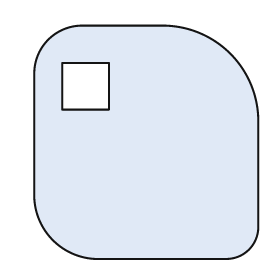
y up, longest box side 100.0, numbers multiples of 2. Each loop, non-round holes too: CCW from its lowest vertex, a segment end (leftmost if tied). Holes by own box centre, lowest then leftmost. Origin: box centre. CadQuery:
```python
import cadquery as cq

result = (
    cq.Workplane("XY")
    .moveTo(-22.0, -50.0)
    .lineTo(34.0, -50.0)
    .threePointArc((44.0, -46.0), (48.0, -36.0))
    .lineTo(48.0, 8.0)
    .threePointArc((36.0, 38.0), (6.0, 50.0))
    .lineTo(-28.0, 50.0)
    .threePointArc((-42.0, 44.0), (-48.0, 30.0))
    .lineTo(-48.0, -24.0)
    .threePointArc((-40.0, -42.0), (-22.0, -50.0))
    .close()
    .moveTo(-36.0, 14.0)
    .lineTo(-16.0, 14.0)
    .lineTo(-16.0, 34.0)
    .lineTo(-36.0, 34.0)
    .close()
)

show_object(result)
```